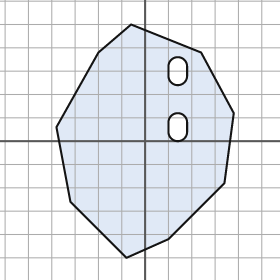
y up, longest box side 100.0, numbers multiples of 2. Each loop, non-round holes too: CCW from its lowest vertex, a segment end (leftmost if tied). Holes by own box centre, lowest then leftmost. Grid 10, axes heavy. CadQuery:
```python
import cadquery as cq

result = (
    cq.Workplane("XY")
    .moveTo(-8.0, -50.0)
    .lineTo(10.0, -42.0)
    .lineTo(34.0, -18.0)
    .lineTo(38.0, 12.0)
    .lineTo(24.0, 38.0)
    .lineTo(-6.0, 50.0)
    .lineTo(-20.0, 38.0)
    .lineTo(-38.0, 6.0)
    .lineTo(-32.0, -26.0)
    .close()
    .moveTo(10.0, 4.0)
    .threePointArc((14.0, 0.0), (18.0, 4.0))
    .lineTo(18.0, 8.0)
    .threePointArc((14.0, 12.0), (10.0, 8.0))
    .close()
    .moveTo(10.0, 28.0)
    .threePointArc((14.0, 24.0), (18.0, 28.0))
    .lineTo(18.0, 32.0)
    .threePointArc((14.0, 36.0), (10.0, 32.0))
    .close()
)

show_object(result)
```